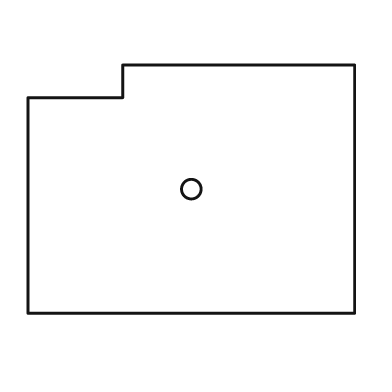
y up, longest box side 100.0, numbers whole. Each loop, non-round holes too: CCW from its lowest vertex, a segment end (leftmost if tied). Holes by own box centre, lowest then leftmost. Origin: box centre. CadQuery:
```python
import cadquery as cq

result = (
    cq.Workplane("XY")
    .moveTo(-50.0, -38.0)
    .lineTo(50.0, -38.0)
    .lineTo(50.0, 38.0)
    .lineTo(-21.0, 38.0)
    .lineTo(-21.0, 28.0)
    .lineTo(-50.0, 28.0)
    .close()
    .moveTo(0.0, 0.0)
    .circle(3.0)
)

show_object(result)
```